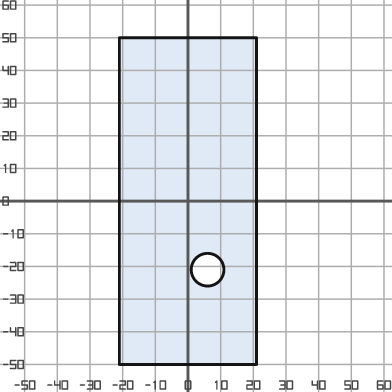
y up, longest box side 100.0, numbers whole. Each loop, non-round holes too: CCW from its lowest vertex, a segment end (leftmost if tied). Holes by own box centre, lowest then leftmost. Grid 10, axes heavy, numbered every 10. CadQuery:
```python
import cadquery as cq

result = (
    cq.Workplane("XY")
    .moveTo(-21.0, -50.0)
    .lineTo(21.0, -50.0)
    .lineTo(21.0, 50.0)
    .lineTo(-21.0, 50.0)
    .close()
    .moveTo(6.0, -21.0)
    .circle(5.0)
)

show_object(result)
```